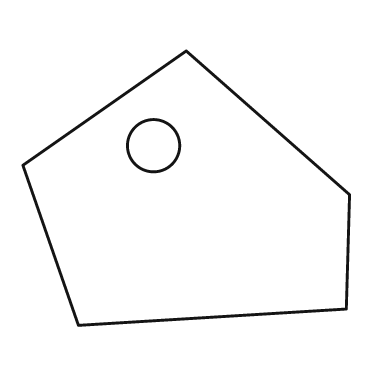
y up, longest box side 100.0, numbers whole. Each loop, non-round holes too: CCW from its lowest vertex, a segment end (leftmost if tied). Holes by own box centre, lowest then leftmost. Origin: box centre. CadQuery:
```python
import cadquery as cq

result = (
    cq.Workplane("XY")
    .moveTo(-33.0, -42.0)
    .lineTo(49.0, -37.0)
    .lineTo(50.0, -2.0)
    .lineTo(0.0, 42.0)
    .lineTo(-50.0, 7.0)
    .close()
    .moveTo(-10.0, 13.0)
    .circle(8.0)
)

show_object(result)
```